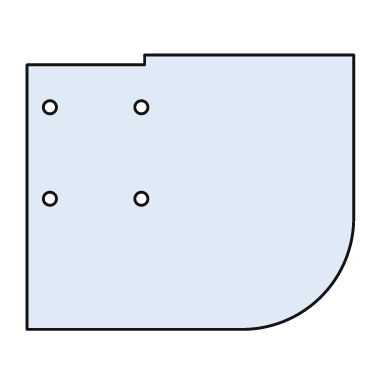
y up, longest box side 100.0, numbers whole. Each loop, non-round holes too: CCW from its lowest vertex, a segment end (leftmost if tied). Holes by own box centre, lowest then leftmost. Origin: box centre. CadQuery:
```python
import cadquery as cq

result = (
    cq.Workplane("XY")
    .moveTo(-50.0, -42.0)
    .lineTo(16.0, -42.0)
    .threePointArc((40.0, -32.0), (50.0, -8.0))
    .lineTo(50.0, 42.0)
    .lineTo(-14.0, 42.0)
    .lineTo(-14.0, 39.0)
    .lineTo(-50.0, 39.0)
    .close()
    .moveTo(-43.0, -2.0)
    .circle(2.0)
    .moveTo(-15.0, -2.0)
    .circle(2.0)
    .moveTo(-43.0, 26.0)
    .circle(2.0)
    .moveTo(-15.0, 26.0)
    .circle(2.0)
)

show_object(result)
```